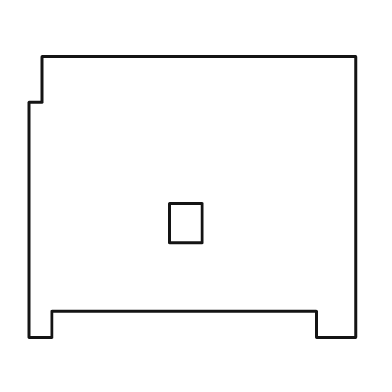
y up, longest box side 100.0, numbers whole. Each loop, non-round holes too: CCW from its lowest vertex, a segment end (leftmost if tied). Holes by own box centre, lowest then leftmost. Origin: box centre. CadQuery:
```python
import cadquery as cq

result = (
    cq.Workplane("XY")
    .moveTo(-50.0, -43.0)
    .lineTo(-43.0, -43.0)
    .lineTo(-43.0, -35.0)
    .lineTo(38.0, -35.0)
    .lineTo(38.0, -43.0)
    .lineTo(50.0, -43.0)
    .lineTo(50.0, 43.0)
    .lineTo(-46.0, 43.0)
    .lineTo(-46.0, 29.0)
    .lineTo(-50.0, 29.0)
    .close()
    .moveTo(-7.0, -14.0)
    .lineTo(3.0, -14.0)
    .lineTo(3.0, -2.0)
    .lineTo(-7.0, -2.0)
    .close()
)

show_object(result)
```